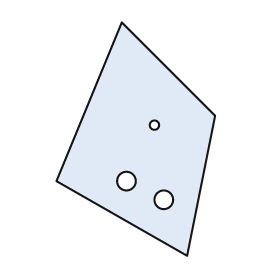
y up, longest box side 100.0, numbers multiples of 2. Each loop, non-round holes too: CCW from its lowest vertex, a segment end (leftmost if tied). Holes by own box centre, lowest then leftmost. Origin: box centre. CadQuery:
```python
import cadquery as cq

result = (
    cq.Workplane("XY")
    .moveTo(22.0, -50.0)
    .lineTo(34.0, 10.0)
    .lineTo(-6.0, 50.0)
    .lineTo(-34.0, -18.0)
    .close()
    .moveTo(12.0, -26.0)
    .circle(4.0)
    .moveTo(-4.0, -18.0)
    .circle(4.0)
    .moveTo(8.0, 6.0)
    .circle(2.0)
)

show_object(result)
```